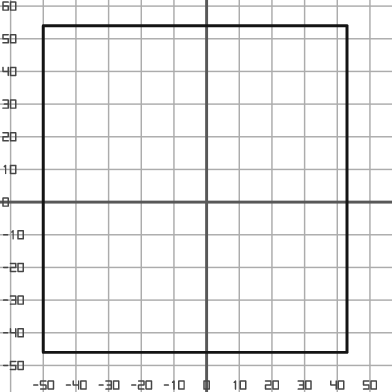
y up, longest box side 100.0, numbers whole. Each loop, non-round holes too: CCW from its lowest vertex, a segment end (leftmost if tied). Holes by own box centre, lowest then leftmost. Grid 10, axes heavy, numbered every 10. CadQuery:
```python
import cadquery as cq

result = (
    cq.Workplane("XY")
    .moveTo(-50.0, -46.0)
    .lineTo(43.0, -46.0)
    .lineTo(43.0, 54.0)
    .lineTo(-50.0, 54.0)
    .close()
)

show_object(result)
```